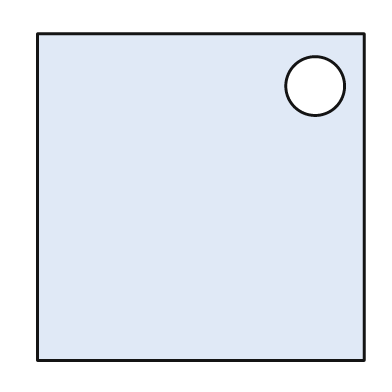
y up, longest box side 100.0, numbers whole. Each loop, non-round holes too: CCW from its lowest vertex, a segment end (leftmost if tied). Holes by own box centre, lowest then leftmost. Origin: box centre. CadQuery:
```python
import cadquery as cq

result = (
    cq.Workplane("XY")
    .moveTo(-50.0, -50.0)
    .lineTo(50.0, -50.0)
    .lineTo(50.0, 50.0)
    .lineTo(-50.0, 50.0)
    .close()
    .moveTo(35.0, 34.0)
    .circle(9.0)
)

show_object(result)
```